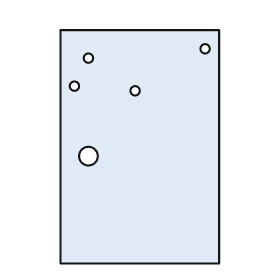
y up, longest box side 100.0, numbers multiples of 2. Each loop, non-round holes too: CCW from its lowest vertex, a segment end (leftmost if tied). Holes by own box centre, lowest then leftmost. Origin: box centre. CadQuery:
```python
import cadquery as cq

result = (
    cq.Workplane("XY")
    .moveTo(-34.0, -50.0)
    .lineTo(34.0, -50.0)
    .lineTo(34.0, 50.0)
    .lineTo(-34.0, 50.0)
    .close()
    .moveTo(-22.0, -4.0)
    .circle(4.0)
    .moveTo(-2.0, 24.0)
    .circle(2.0)
    .moveTo(-28.0, 26.0)
    .circle(2.0)
    .moveTo(-22.0, 38.0)
    .circle(2.0)
    .moveTo(28.0, 42.0)
    .circle(2.0)
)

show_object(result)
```